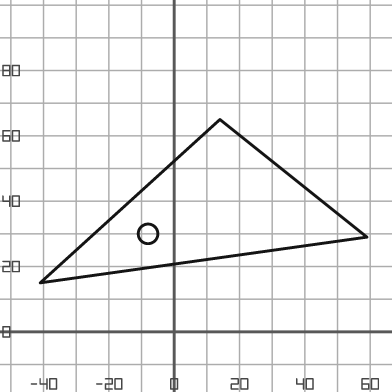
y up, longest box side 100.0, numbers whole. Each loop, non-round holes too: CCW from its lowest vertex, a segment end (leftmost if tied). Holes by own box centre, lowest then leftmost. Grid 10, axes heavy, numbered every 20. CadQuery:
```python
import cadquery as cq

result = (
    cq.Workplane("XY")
    .moveTo(-41.0, 15.0)
    .lineTo(59.0, 29.0)
    .lineTo(14.0, 65.0)
    .close()
    .moveTo(-8.0, 30.0)
    .circle(3.0)
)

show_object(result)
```